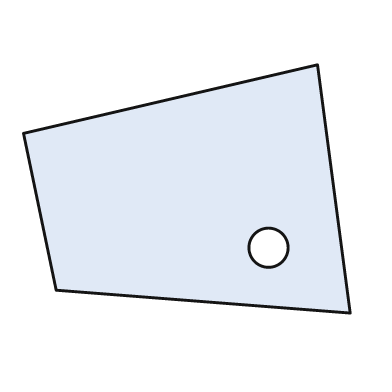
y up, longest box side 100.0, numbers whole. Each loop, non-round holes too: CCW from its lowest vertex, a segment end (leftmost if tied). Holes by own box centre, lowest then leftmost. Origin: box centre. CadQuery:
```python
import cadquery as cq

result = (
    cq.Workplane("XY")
    .moveTo(50.0, -38.0)
    .lineTo(40.0, 38.0)
    .lineTo(-50.0, 17.0)
    .lineTo(-40.0, -31.0)
    .close()
    .moveTo(25.0, -18.0)
    .circle(6.0)
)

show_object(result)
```